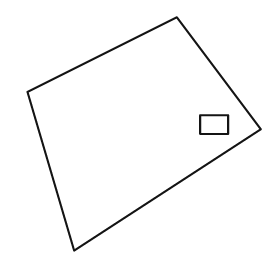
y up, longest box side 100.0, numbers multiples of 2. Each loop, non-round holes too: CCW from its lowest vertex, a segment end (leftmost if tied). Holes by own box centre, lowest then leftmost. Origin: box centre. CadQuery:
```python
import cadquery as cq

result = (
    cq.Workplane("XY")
    .moveTo(-30.0, -50.0)
    .lineTo(50.0, 2.0)
    .lineTo(14.0, 50.0)
    .lineTo(-50.0, 18.0)
    .close()
    .moveTo(24.0, 0.0)
    .lineTo(36.0, 0.0)
    .lineTo(36.0, 8.0)
    .lineTo(24.0, 8.0)
    .close()
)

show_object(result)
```